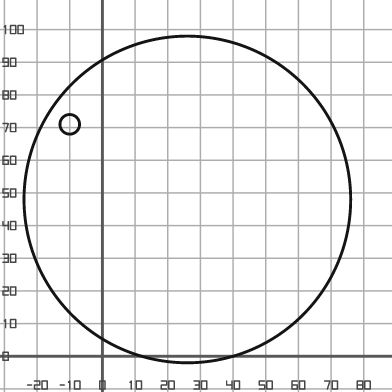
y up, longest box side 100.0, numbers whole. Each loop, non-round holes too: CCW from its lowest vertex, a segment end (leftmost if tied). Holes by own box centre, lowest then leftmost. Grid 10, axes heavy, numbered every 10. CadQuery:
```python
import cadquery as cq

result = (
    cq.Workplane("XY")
    .moveTo(26.0, 48.0)
    .circle(50.0)
    .moveTo(-10.0, 71.0)
    .circle(3.0)
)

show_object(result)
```